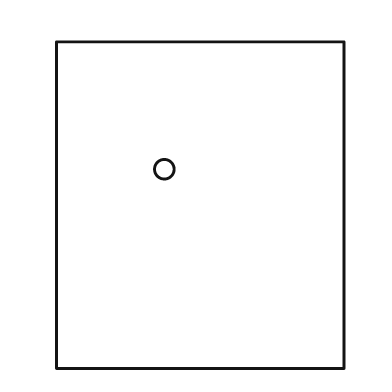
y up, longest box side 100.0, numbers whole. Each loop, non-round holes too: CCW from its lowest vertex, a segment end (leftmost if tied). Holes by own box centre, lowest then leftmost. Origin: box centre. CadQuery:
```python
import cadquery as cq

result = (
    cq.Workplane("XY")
    .moveTo(-44.0, -50.0)
    .lineTo(44.0, -50.0)
    .lineTo(44.0, 50.0)
    .lineTo(-44.0, 50.0)
    .close()
    .moveTo(-11.0, 11.0)
    .circle(3.0)
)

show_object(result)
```